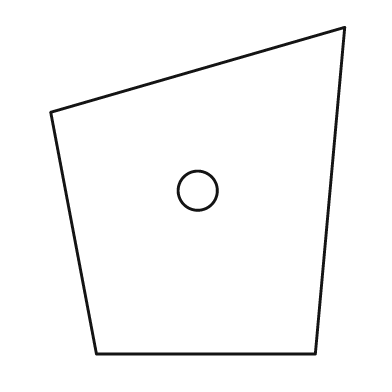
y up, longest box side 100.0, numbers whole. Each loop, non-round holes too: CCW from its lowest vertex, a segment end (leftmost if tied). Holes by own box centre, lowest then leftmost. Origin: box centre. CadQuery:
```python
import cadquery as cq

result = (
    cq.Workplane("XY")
    .moveTo(-31.0, -50.0)
    .lineTo(36.0, -50.0)
    .lineTo(45.0, 50.0)
    .lineTo(-45.0, 24.0)
    .close()
    .moveTo(0.0, 0.0)
    .circle(6.0)
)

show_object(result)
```